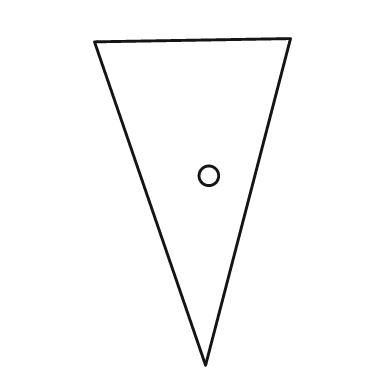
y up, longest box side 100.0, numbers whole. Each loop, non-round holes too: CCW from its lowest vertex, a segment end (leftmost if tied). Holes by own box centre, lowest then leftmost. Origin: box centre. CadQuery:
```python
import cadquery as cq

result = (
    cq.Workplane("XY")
    .moveTo(4.0, -50.0)
    .lineTo(30.0, 50.0)
    .lineTo(-30.0, 49.0)
    .close()
    .moveTo(5.0, 8.0)
    .circle(3.0)
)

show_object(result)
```